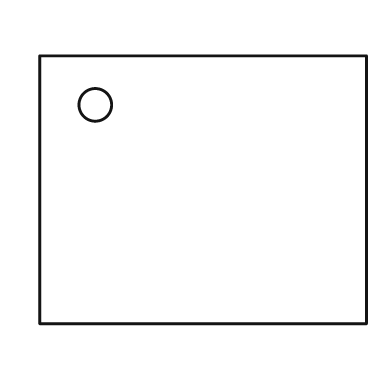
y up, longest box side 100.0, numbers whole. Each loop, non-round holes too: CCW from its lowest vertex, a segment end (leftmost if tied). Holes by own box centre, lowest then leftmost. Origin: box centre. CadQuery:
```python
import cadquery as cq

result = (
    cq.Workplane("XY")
    .moveTo(-50.0, -41.0)
    .lineTo(50.0, -41.0)
    .lineTo(50.0, 41.0)
    .lineTo(-50.0, 41.0)
    .close()
    .moveTo(-33.0, 26.0)
    .circle(5.0)
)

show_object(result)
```